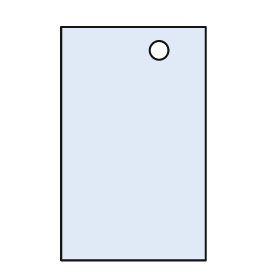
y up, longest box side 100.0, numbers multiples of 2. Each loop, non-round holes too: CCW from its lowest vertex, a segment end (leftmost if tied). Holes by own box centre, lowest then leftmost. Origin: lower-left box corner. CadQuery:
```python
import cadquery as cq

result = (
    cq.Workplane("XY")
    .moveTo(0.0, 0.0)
    .lineTo(62.0, 0.0)
    .lineTo(62.0, 100.0)
    .lineTo(0.0, 100.0)
    .close()
    .moveTo(42.0, 90.0)
    .circle(4.0)
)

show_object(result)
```